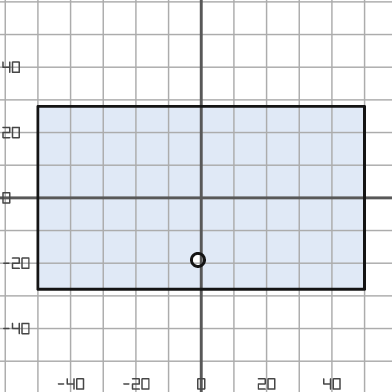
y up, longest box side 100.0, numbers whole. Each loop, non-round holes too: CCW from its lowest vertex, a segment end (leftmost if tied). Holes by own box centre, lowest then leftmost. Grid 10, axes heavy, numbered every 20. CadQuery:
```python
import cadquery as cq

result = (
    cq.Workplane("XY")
    .moveTo(-50.0, -28.0)
    .lineTo(50.0, -28.0)
    .lineTo(50.0, 28.0)
    .lineTo(-50.0, 28.0)
    .close()
    .moveTo(-1.0, -19.0)
    .circle(2.0)
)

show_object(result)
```